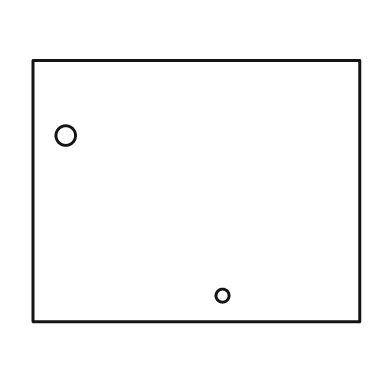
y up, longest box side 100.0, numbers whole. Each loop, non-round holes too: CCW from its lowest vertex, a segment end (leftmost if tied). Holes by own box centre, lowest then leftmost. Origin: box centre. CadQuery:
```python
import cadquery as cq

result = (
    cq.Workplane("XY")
    .moveTo(-50.0, -40.0)
    .lineTo(50.0, -40.0)
    .lineTo(50.0, 40.0)
    .lineTo(-50.0, 40.0)
    .close()
    .moveTo(8.0, -32.0)
    .circle(2.0)
    .moveTo(-40.0, 17.0)
    .circle(3.0)
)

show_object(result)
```